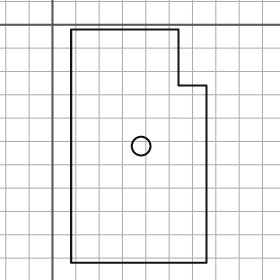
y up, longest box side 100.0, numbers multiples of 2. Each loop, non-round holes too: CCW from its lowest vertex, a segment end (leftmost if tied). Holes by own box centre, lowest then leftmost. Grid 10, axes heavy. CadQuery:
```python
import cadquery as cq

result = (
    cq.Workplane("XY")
    .moveTo(8.0, -102.0)
    .lineTo(66.0, -102.0)
    .lineTo(66.0, -26.0)
    .lineTo(54.0, -26.0)
    .lineTo(54.0, -2.0)
    .lineTo(8.0, -2.0)
    .close()
    .moveTo(38.0, -52.0)
    .circle(4.0)
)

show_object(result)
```